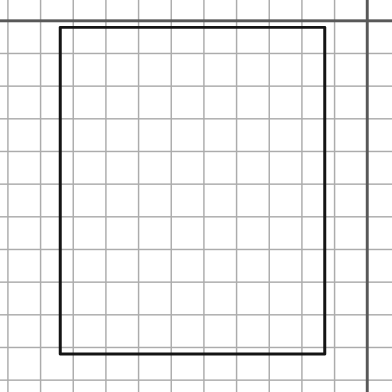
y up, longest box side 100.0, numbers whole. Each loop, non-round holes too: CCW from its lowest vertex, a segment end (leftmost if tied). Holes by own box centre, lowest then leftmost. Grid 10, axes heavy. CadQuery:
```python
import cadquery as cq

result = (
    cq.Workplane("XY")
    .moveTo(-94.0, -102.0)
    .lineTo(-13.0, -102.0)
    .lineTo(-13.0, -2.0)
    .lineTo(-94.0, -2.0)
    .close()
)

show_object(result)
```